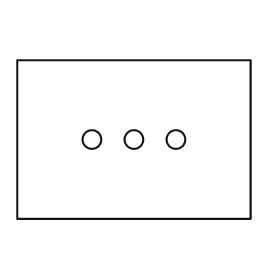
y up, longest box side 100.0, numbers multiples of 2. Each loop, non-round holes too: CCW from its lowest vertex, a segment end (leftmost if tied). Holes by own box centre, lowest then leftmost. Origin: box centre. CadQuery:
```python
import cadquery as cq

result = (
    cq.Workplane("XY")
    .moveTo(-50.0, -34.0)
    .lineTo(50.0, -34.0)
    .lineTo(50.0, 34.0)
    .lineTo(-50.0, 34.0)
    .close()
    .moveTo(-18.0, 0.0)
    .circle(4.0)
    .moveTo(0.0, 0.0)
    .circle(4.0)
    .moveTo(18.0, 0.0)
    .circle(4.0)
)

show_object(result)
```